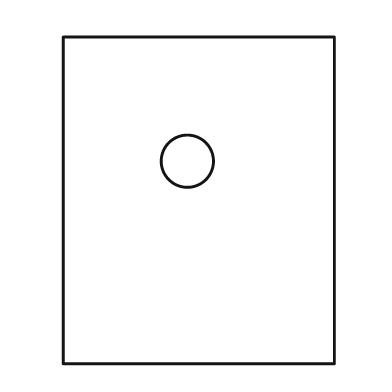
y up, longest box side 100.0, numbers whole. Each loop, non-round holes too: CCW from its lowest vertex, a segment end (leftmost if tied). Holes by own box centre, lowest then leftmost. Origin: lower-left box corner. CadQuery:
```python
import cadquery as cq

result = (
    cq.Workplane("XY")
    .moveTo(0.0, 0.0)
    .lineTo(83.0, 0.0)
    .lineTo(83.0, 100.0)
    .lineTo(0.0, 100.0)
    .close()
    .moveTo(38.0, 62.0)
    .circle(8.0)
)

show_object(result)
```